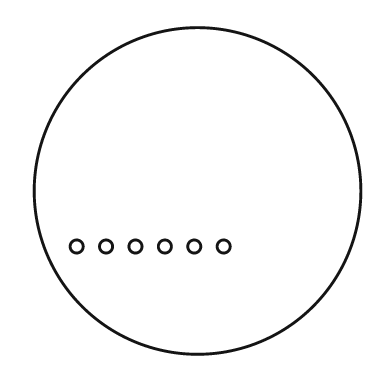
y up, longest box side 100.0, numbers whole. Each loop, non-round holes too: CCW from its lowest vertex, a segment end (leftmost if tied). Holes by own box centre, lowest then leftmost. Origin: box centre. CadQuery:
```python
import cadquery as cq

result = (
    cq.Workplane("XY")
    .moveTo(0.0, 0.0)
    .circle(50.0)
    .moveTo(-37.0, -17.0)
    .circle(2.0)
    .moveTo(-28.0, -17.0)
    .circle(2.0)
    .moveTo(-19.0, -17.0)
    .circle(2.0)
    .moveTo(-10.0, -17.0)
    .circle(2.0)
    .moveTo(-1.0, -17.0)
    .circle(2.0)
    .moveTo(8.0, -17.0)
    .circle(2.0)
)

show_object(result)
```